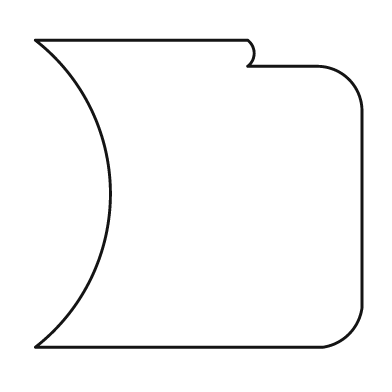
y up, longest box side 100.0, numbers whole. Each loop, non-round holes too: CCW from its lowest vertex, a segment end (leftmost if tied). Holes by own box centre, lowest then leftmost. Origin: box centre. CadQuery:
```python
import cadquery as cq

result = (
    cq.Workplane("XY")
    .moveTo(-50.0, -47.0)
    .lineTo(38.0, -47.0)
    .threePointArc((46.0, -43.0), (50.0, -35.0))
    .lineTo(50.0, 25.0)
    .threePointArc((46.0, 35.0), (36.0, 39.0))
    .lineTo(15.0, 39.0)
    .threePointArc((17.0, 43.0), (15.0, 47.0))
    .lineTo(-50.0, 47.0)
    .threePointArc((-27.0, 0.0), (-50.0, -47.0))
    .close()
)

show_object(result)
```